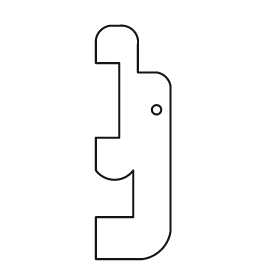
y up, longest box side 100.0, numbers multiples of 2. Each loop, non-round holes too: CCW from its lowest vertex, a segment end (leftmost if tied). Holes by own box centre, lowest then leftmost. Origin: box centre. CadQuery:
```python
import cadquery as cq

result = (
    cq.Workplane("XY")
    .moveTo(-16.0, -50.0)
    .lineTo(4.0, -50.0)
    .threePointArc((12.0, -46.0), (16.0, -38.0))
    .lineTo(16.0, 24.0)
    .threePointArc((14.0, 28.0), (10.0, 30.0))
    .lineTo(2.0, 30.0)
    .lineTo(2.0, 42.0)
    .threePointArc((0.0, 48.0), (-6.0, 50.0))
    .lineTo(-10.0, 50.0)
    .threePointArc((-14.0, 48.0), (-16.0, 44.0))
    .lineTo(-16.0, 34.0)
    .lineTo(-6.0, 34.0)
    .lineTo(-6.0, 2.0)
    .lineTo(-16.0, 2.0)
    .lineTo(-16.0, -12.0)
    .threePointArc((-8.0, -16.0), (0.0, -12.0))
    .lineTo(0.0, -32.0)
    .lineTo(-16.0, -32.0)
    .close()
    .moveTo(10.0, 14.0)
    .circle(2.0)
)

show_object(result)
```